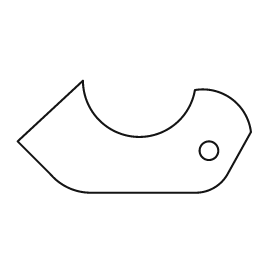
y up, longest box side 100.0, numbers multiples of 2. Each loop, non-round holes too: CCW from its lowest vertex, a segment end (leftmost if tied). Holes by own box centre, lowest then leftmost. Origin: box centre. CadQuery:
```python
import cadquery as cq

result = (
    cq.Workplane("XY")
    .moveTo(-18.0, -24.0)
    .lineTo(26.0, -24.0)
    .threePointArc((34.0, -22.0), (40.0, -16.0))
    .lineTo(50.0, 2.0)
    .threePointArc((42.0, 16.0), (26.0, 20.0))
    .threePointArc((0.0, 0.0), (-22.0, 24.0))
    .lineTo(-50.0, -2.0)
    .lineTo(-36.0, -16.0)
    .threePointArc((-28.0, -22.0), (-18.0, -24.0))
    .close()
    .moveTo(32.0, -6.0)
    .circle(4.0)
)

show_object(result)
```